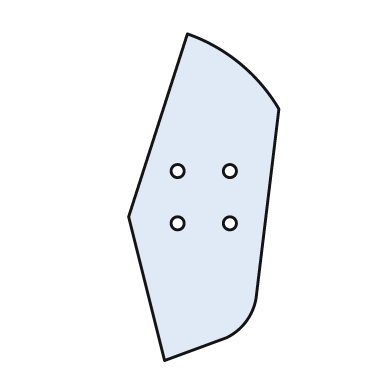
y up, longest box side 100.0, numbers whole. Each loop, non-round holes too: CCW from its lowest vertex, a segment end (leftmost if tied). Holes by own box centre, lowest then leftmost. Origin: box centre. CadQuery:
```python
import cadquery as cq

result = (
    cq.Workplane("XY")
    .moveTo(-12.0, -50.0)
    .lineTo(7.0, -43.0)
    .threePointArc((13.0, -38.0), (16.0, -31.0))
    .lineTo(23.0, 27.0)
    .threePointArc((11.0, 41.0), (-5.0, 50.0))
    .lineTo(-23.0, -6.0)
    .close()
    .moveTo(-8.0, -8.0)
    .circle(2.0)
    .moveTo(8.0, -8.0)
    .circle(2.0)
    .moveTo(-8.0, 8.0)
    .circle(2.0)
    .moveTo(8.0, 8.0)
    .circle(2.0)
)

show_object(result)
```